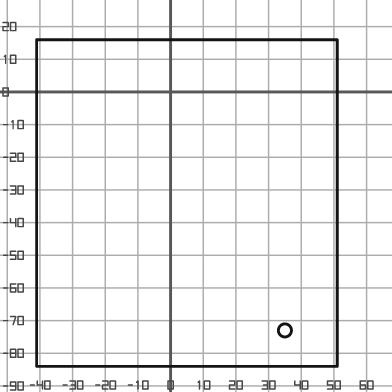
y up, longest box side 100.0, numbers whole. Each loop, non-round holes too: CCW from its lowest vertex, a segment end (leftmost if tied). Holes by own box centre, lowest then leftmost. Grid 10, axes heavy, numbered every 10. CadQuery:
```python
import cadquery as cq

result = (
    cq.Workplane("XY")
    .moveTo(-41.0, -84.0)
    .lineTo(51.0, -84.0)
    .lineTo(51.0, 16.0)
    .lineTo(-41.0, 16.0)
    .close()
    .moveTo(35.0, -73.0)
    .circle(2.0)
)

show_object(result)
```